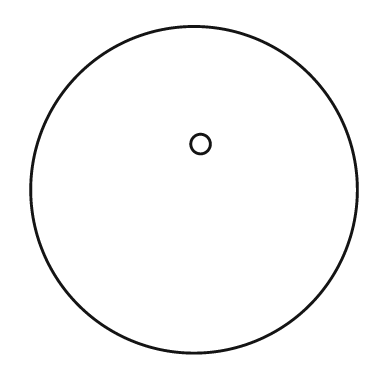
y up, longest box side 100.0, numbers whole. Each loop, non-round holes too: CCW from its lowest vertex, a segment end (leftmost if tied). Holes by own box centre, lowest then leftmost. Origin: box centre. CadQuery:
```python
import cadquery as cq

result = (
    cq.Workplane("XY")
    .moveTo(0.0, 0.0)
    .circle(50.0)
    .moveTo(2.0, 14.0)
    .circle(3.0)
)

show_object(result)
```